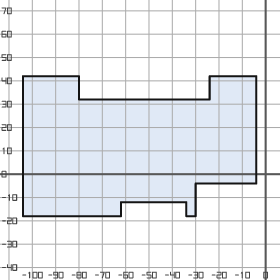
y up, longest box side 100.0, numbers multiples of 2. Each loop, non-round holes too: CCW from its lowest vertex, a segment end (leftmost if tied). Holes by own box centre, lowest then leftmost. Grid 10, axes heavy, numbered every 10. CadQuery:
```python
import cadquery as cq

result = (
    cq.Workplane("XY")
    .moveTo(-104.0, -18.0)
    .lineTo(-62.0, -18.0)
    .lineTo(-62.0, -12.0)
    .lineTo(-34.0, -12.0)
    .lineTo(-34.0, -18.0)
    .lineTo(-30.0, -18.0)
    .lineTo(-30.0, -4.0)
    .lineTo(-4.0, -4.0)
    .lineTo(-4.0, 42.0)
    .lineTo(-24.0, 42.0)
    .lineTo(-24.0, 32.0)
    .lineTo(-80.0, 32.0)
    .lineTo(-80.0, 42.0)
    .lineTo(-104.0, 42.0)
    .close()
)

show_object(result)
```